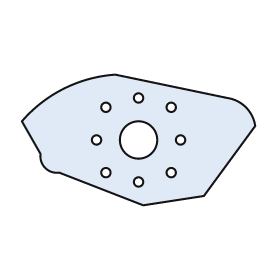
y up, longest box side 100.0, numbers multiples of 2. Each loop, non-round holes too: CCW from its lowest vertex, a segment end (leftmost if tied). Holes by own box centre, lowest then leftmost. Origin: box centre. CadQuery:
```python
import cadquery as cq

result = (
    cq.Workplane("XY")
    .moveTo(2.0, -28.0)
    .lineTo(28.0, -24.0)
    .lineTo(50.0, 6.0)
    .threePointArc((46.0, 14.0), (38.0, 18.0))
    .lineTo(-10.0, 28.0)
    .threePointArc((-32.0, 22.0), (-50.0, 8.0))
    .lineTo(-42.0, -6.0)
    .threePointArc((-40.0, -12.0), (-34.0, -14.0))
    .close()
    .moveTo(0.0, -18.0)
    .circle(2.0)
    .moveTo(-14.0, -14.0)
    .circle(2.0)
    .moveTo(14.0, -14.0)
    .circle(2.0)
    .moveTo(-18.0, 0.0)
    .circle(2.0)
    .moveTo(0.0, 0.0)
    .circle(8.0)
    .moveTo(18.0, 0.0)
    .circle(2.0)
    .moveTo(-14.0, 14.0)
    .circle(2.0)
    .moveTo(14.0, 14.0)
    .circle(2.0)
    .moveTo(0.0, 18.0)
    .circle(2.0)
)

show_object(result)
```